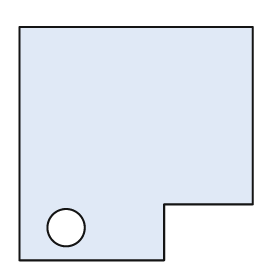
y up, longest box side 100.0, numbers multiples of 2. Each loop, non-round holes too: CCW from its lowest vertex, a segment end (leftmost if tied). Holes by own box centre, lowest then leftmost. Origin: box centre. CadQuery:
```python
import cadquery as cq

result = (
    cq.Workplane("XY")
    .moveTo(-50.0, -50.0)
    .lineTo(12.0, -50.0)
    .lineTo(12.0, -26.0)
    .lineTo(50.0, -26.0)
    .lineTo(50.0, 50.0)
    .lineTo(-50.0, 50.0)
    .close()
    .moveTo(-30.0, -36.0)
    .circle(8.0)
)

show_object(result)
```